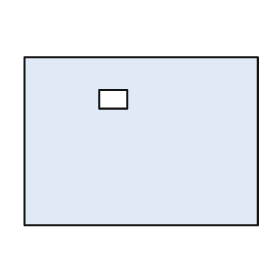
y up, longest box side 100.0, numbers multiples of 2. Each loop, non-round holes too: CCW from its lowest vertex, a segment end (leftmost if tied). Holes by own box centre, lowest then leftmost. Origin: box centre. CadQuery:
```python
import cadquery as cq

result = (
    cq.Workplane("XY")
    .moveTo(-50.0, -36.0)
    .lineTo(50.0, -36.0)
    .lineTo(50.0, 36.0)
    .lineTo(-50.0, 36.0)
    .close()
    .moveTo(-18.0, 14.0)
    .lineTo(-6.0, 14.0)
    .lineTo(-6.0, 22.0)
    .lineTo(-18.0, 22.0)
    .close()
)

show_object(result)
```